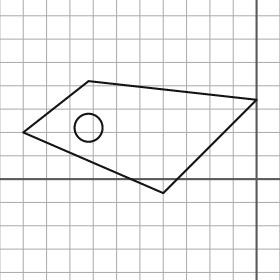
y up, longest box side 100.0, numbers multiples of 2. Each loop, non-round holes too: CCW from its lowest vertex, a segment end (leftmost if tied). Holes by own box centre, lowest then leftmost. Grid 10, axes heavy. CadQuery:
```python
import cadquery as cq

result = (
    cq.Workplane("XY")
    .moveTo(-40.0, -6.0)
    .lineTo(0.0, 34.0)
    .lineTo(-72.0, 42.0)
    .lineTo(-100.0, 20.0)
    .close()
    .moveTo(-72.0, 22.0)
    .circle(6.0)
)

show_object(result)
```